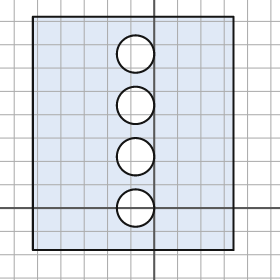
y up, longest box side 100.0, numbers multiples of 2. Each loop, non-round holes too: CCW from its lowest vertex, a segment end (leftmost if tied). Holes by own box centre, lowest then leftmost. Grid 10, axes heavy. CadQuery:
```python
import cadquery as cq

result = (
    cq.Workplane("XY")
    .moveTo(-52.0, -18.0)
    .lineTo(34.0, -18.0)
    .lineTo(34.0, 82.0)
    .lineTo(-52.0, 82.0)
    .close()
    .moveTo(-8.0, 0.0)
    .circle(8.0)
    .moveTo(-8.0, 22.0)
    .circle(8.0)
    .moveTo(-8.0, 44.0)
    .circle(8.0)
    .moveTo(-8.0, 66.0)
    .circle(8.0)
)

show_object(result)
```